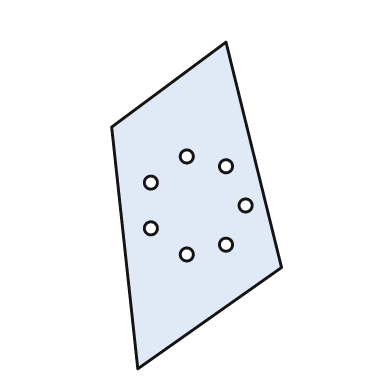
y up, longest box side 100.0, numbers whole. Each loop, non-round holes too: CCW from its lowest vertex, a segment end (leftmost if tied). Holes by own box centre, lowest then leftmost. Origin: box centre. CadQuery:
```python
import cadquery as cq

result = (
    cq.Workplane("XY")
    .moveTo(-18.0, -50.0)
    .lineTo(26.0, -19.0)
    .lineTo(9.0, 50.0)
    .lineTo(-26.0, 24.0)
    .close()
    .moveTo(-3.0, -15.0)
    .circle(2.0)
    .moveTo(9.0, -12.0)
    .circle(2.0)
    .moveTo(-14.0, -7.0)
    .circle(2.0)
    .moveTo(15.0, 0.0)
    .circle(2.0)
    .moveTo(-14.0, 7.0)
    .circle(2.0)
    .moveTo(9.0, 12.0)
    .circle(2.0)
    .moveTo(-3.0, 15.0)
    .circle(2.0)
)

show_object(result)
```